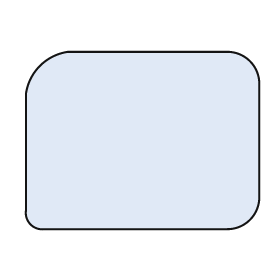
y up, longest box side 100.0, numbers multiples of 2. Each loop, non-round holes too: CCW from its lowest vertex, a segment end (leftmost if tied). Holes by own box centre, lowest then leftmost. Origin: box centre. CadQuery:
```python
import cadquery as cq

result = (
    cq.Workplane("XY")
    .moveTo(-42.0, -38.0)
    .lineTo(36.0, -38.0)
    .threePointArc((46.0, -34.0), (50.0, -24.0))
    .lineTo(50.0, 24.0)
    .threePointArc((46.0, 34.0), (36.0, 38.0))
    .lineTo(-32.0, 38.0)
    .threePointArc((-44.0, 32.0), (-50.0, 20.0))
    .lineTo(-50.0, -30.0)
    .threePointArc((-48.0, -36.0), (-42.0, -38.0))
    .close()
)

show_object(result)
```